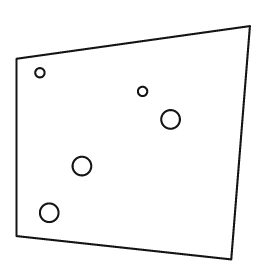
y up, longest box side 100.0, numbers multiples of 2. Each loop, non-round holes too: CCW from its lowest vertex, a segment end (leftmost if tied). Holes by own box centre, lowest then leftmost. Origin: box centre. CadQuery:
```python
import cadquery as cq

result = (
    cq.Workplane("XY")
    .moveTo(42.0, -50.0)
    .lineTo(50.0, 50.0)
    .lineTo(-50.0, 36.0)
    .lineTo(-50.0, -40.0)
    .close()
    .moveTo(-36.0, -30.0)
    .circle(4.0)
    .moveTo(-22.0, -10.0)
    .circle(4.0)
    .moveTo(16.0, 10.0)
    .circle(4.0)
    .moveTo(4.0, 22.0)
    .circle(2.0)
    .moveTo(-40.0, 30.0)
    .circle(2.0)
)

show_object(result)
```